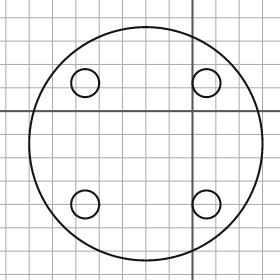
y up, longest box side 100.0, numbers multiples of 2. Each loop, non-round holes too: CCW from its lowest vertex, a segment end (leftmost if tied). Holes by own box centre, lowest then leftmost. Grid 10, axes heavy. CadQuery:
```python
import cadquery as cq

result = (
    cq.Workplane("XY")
    .moveTo(-20.0, -14.0)
    .circle(50.0)
    .moveTo(-46.0, -40.0)
    .circle(6.0)
    .moveTo(6.0, -40.0)
    .circle(6.0)
    .moveTo(-46.0, 12.0)
    .circle(6.0)
    .moveTo(6.0, 12.0)
    .circle(6.0)
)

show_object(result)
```